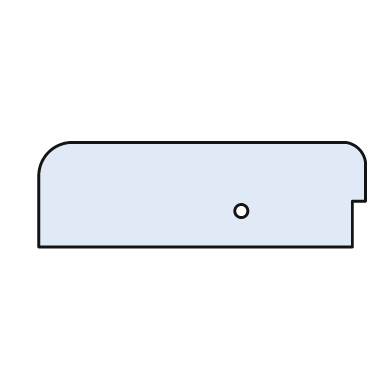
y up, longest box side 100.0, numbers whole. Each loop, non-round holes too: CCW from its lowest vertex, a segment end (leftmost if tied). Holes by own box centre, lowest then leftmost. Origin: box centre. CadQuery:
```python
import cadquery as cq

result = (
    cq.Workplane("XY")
    .moveTo(-50.0, -16.0)
    .lineTo(46.0, -16.0)
    .lineTo(46.0, -2.0)
    .lineTo(50.0, -2.0)
    .lineTo(50.0, 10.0)
    .threePointArc((48.0, 14.0), (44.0, 16.0))
    .lineTo(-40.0, 16.0)
    .threePointArc((-47.0, 13.0), (-50.0, 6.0))
    .close()
    .moveTo(12.0, -5.0)
    .circle(2.0)
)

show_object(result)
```